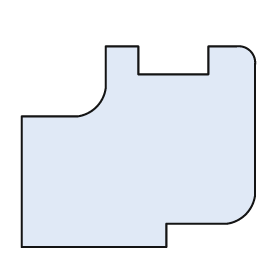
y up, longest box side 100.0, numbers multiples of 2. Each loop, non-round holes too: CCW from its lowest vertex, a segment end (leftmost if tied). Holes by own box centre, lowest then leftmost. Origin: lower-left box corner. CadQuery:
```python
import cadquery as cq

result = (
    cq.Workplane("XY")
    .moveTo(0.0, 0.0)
    .lineTo(62.0, 0.0)
    .lineTo(62.0, 10.0)
    .lineTo(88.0, 10.0)
    .threePointArc((96.0, 14.0), (100.0, 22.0))
    .lineTo(100.0, 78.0)
    .threePointArc((98.0, 84.0), (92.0, 86.0))
    .lineTo(80.0, 86.0)
    .lineTo(80.0, 74.0)
    .lineTo(50.0, 74.0)
    .lineTo(50.0, 86.0)
    .lineTo(36.0, 86.0)
    .lineTo(36.0, 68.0)
    .threePointArc((32.0, 60.0), (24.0, 56.0))
    .lineTo(0.0, 56.0)
    .close()
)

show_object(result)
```